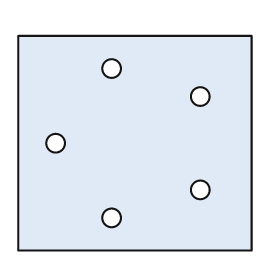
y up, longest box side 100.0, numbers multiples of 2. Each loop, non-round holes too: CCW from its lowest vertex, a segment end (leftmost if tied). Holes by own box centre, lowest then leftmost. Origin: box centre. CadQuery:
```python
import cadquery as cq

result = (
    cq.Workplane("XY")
    .moveTo(-50.0, -46.0)
    .lineTo(50.0, -46.0)
    .lineTo(50.0, 46.0)
    .lineTo(-50.0, 46.0)
    .close()
    .moveTo(-10.0, -32.0)
    .circle(4.0)
    .moveTo(28.0, -20.0)
    .circle(4.0)
    .moveTo(-34.0, 0.0)
    .circle(4.0)
    .moveTo(28.0, 20.0)
    .circle(4.0)
    .moveTo(-10.0, 32.0)
    .circle(4.0)
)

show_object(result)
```